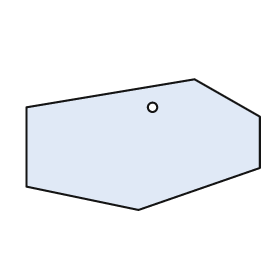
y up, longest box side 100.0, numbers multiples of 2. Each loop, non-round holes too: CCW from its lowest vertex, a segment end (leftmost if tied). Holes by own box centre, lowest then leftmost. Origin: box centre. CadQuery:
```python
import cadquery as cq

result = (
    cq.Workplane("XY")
    .moveTo(-2.0, -28.0)
    .lineTo(50.0, -10.0)
    .lineTo(50.0, 12.0)
    .lineTo(22.0, 28.0)
    .lineTo(-50.0, 16.0)
    .lineTo(-50.0, -18.0)
    .close()
    .moveTo(4.0, 16.0)
    .circle(2.0)
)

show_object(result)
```